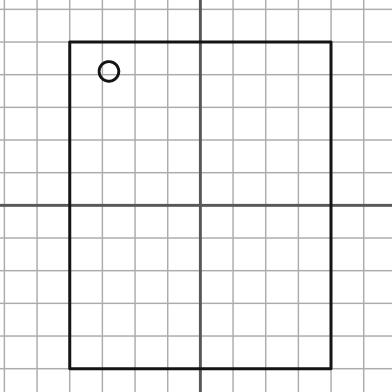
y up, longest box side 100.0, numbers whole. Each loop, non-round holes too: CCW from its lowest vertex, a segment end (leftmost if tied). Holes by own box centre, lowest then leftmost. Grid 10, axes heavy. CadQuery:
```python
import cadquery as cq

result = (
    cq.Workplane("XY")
    .moveTo(-40.0, -50.0)
    .lineTo(40.0, -50.0)
    .lineTo(40.0, 50.0)
    .lineTo(-40.0, 50.0)
    .close()
    .moveTo(-28.0, 41.0)
    .circle(3.0)
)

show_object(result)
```